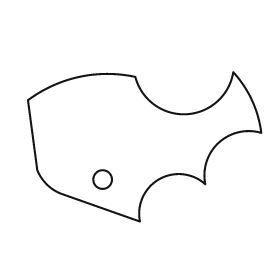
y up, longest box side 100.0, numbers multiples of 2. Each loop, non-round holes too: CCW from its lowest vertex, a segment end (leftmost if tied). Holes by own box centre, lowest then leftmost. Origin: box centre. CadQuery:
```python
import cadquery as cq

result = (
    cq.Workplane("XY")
    .moveTo(-2.0, -32.0)
    .threePointArc((6.0, -14.0), (26.0, -16.0))
    .threePointArc((32.0, 2.0), (50.0, 6.0))
    .threePointArc((46.0, 20.0), (38.0, 32.0))
    .threePointArc((18.0, 14.0), (-4.0, 30.0))
    .threePointArc((-28.0, 30.0), (-50.0, 20.0))
    .lineTo(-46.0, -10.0)
    .threePointArc((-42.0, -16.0), (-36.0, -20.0))
    .close()
    .moveTo(-18.0, -14.0)
    .circle(4.0)
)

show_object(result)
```